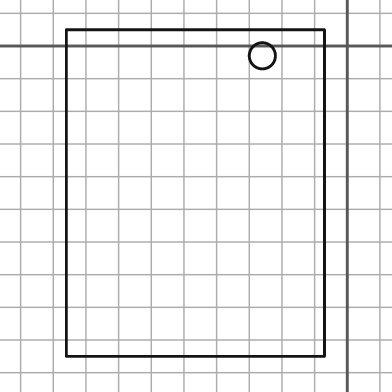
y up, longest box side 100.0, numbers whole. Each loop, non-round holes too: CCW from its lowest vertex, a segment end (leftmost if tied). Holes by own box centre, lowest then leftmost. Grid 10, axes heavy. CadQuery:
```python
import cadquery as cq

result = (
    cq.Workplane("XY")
    .moveTo(-86.0, -95.0)
    .lineTo(-7.0, -95.0)
    .lineTo(-7.0, 5.0)
    .lineTo(-86.0, 5.0)
    .close()
    .moveTo(-26.0, -3.0)
    .circle(4.0)
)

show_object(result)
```